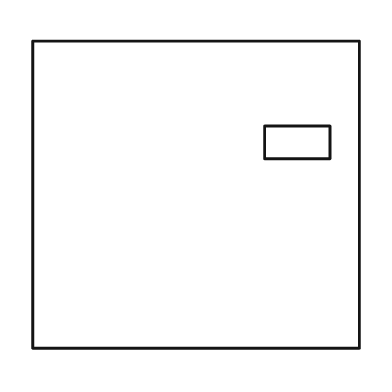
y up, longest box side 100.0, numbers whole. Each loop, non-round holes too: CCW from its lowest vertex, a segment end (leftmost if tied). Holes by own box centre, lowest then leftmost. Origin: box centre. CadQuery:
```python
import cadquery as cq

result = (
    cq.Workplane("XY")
    .moveTo(-50.0, -47.0)
    .lineTo(50.0, -47.0)
    .lineTo(50.0, 47.0)
    .lineTo(-50.0, 47.0)
    .close()
    .moveTo(21.0, 11.0)
    .lineTo(41.0, 11.0)
    .lineTo(41.0, 21.0)
    .lineTo(21.0, 21.0)
    .close()
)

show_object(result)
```